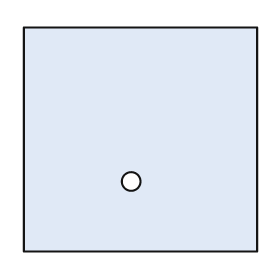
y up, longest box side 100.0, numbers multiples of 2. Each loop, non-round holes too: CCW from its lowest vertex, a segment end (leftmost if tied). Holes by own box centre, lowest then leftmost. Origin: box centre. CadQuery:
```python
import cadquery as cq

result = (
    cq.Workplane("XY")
    .moveTo(-50.0, -48.0)
    .lineTo(50.0, -48.0)
    .lineTo(50.0, 48.0)
    .lineTo(-50.0, 48.0)
    .close()
    .moveTo(-4.0, -18.0)
    .circle(4.0)
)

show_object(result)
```